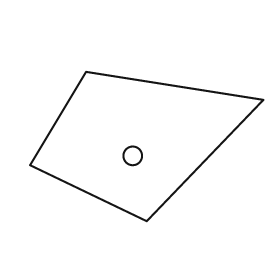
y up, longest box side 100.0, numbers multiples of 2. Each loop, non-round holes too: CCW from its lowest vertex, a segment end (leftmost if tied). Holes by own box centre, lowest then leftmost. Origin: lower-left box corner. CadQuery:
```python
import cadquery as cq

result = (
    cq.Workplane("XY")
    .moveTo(50.0, 0.0)
    .lineTo(100.0, 52.0)
    .lineTo(24.0, 64.0)
    .lineTo(0.0, 24.0)
    .close()
    .moveTo(44.0, 28.0)
    .circle(4.0)
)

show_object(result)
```